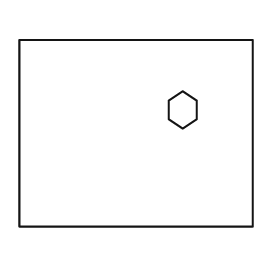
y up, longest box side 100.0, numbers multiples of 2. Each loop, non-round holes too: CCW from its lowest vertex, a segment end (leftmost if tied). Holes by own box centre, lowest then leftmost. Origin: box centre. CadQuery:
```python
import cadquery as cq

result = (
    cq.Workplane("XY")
    .moveTo(-50.0, -40.0)
    .lineTo(50.0, -40.0)
    .lineTo(50.0, 40.0)
    .lineTo(-50.0, 40.0)
    .close()
    .moveTo(20.0, 2.0)
    .lineTo(26.0, 6.0)
    .lineTo(26.0, 14.0)
    .lineTo(20.0, 18.0)
    .lineTo(14.0, 14.0)
    .lineTo(14.0, 6.0)
    .close()
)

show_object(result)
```